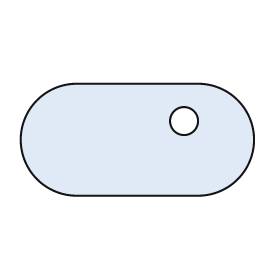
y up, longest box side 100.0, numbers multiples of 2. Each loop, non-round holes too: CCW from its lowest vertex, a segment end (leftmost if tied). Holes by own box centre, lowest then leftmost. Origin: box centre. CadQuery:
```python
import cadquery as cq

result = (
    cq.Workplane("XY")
    .moveTo(-26.0, -24.0)
    .lineTo(26.0, -24.0)
    .threePointArc((50.0, 0.0), (26.0, 24.0))
    .lineTo(-26.0, 24.0)
    .threePointArc((-50.0, 0.0), (-26.0, -24.0))
    .close()
    .moveTo(20.0, 8.0)
    .circle(6.0)
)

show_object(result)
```